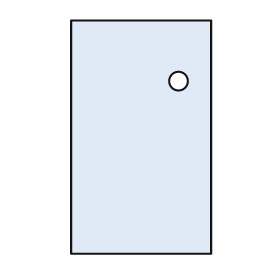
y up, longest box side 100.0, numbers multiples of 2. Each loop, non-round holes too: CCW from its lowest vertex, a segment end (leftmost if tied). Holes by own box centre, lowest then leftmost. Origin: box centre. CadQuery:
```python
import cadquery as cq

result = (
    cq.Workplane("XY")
    .moveTo(-30.0, -50.0)
    .lineTo(30.0, -50.0)
    .lineTo(30.0, 50.0)
    .lineTo(-30.0, 50.0)
    .close()
    .moveTo(16.0, 24.0)
    .circle(4.0)
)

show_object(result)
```